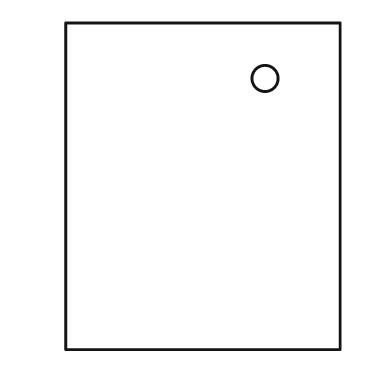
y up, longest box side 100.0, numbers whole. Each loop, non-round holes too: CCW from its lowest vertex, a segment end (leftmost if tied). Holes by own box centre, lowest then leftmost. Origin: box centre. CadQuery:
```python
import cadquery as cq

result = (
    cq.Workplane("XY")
    .moveTo(-42.0, -50.0)
    .lineTo(42.0, -50.0)
    .lineTo(42.0, 50.0)
    .lineTo(-42.0, 50.0)
    .close()
    .moveTo(19.0, 33.0)
    .circle(4.0)
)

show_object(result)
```